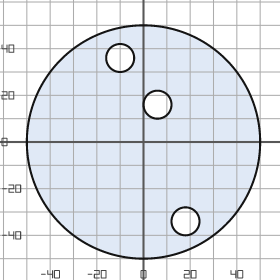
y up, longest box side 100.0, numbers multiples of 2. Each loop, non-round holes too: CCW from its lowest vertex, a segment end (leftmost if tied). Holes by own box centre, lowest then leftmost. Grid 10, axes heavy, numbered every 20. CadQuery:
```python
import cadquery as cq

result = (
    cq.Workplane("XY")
    .moveTo(0.0, 0.0)
    .circle(50.0)
    .moveTo(18.0, -34.0)
    .circle(6.0)
    .moveTo(6.0, 16.0)
    .circle(6.0)
    .moveTo(-10.0, 36.0)
    .circle(6.0)
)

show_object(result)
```